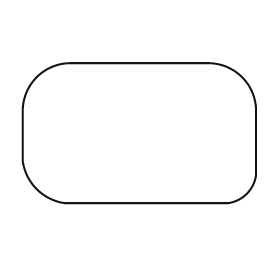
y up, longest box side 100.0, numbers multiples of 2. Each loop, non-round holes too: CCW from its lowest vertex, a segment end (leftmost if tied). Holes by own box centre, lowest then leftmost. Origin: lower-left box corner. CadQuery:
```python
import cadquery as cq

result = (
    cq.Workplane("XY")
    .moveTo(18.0, 0.0)
    .lineTo(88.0, 0.0)
    .threePointArc((96.0, 4.0), (100.0, 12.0))
    .lineTo(100.0, 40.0)
    .threePointArc((94.0, 54.0), (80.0, 60.0))
    .lineTo(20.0, 60.0)
    .threePointArc((6.0, 54.0), (0.0, 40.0))
    .lineTo(0.0, 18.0)
    .threePointArc((6.0, 6.0), (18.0, 0.0))
    .close()
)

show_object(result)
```